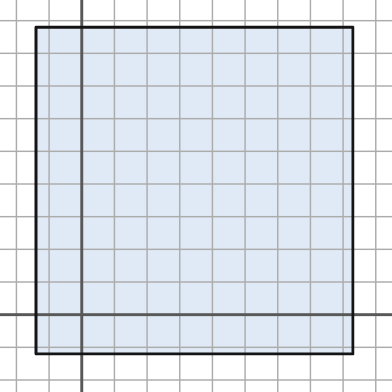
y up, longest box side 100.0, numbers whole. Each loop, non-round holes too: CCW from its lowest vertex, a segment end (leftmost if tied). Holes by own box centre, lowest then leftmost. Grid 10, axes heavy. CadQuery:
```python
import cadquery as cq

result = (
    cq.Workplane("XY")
    .moveTo(-14.0, -12.0)
    .lineTo(83.0, -12.0)
    .lineTo(83.0, 88.0)
    .lineTo(-14.0, 88.0)
    .close()
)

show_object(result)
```